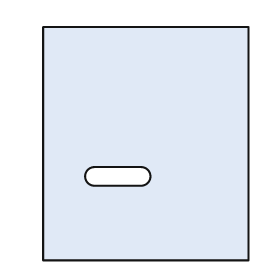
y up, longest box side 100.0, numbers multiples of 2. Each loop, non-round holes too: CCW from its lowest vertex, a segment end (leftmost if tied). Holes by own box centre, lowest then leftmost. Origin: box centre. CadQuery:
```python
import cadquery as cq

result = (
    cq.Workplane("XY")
    .moveTo(-44.0, -50.0)
    .lineTo(44.0, -50.0)
    .lineTo(44.0, 50.0)
    .lineTo(-44.0, 50.0)
    .close()
    .moveTo(-22.0, -18.0)
    .lineTo(-2.0, -18.0)
    .threePointArc((2.0, -14.0), (-2.0, -10.0))
    .lineTo(-22.0, -10.0)
    .threePointArc((-26.0, -14.0), (-22.0, -18.0))
    .close()
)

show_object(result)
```